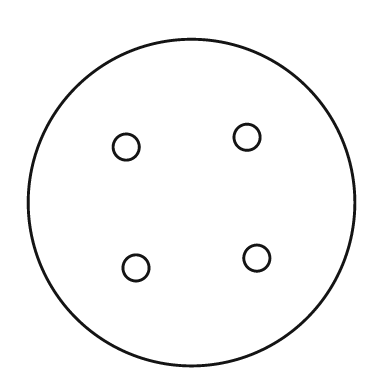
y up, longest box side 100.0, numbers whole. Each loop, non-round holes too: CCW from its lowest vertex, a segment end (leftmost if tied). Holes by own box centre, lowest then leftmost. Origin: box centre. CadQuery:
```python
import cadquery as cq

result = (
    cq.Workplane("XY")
    .moveTo(0.0, 0.0)
    .circle(50.0)
    .moveTo(-17.0, -20.0)
    .circle(4.0)
    .moveTo(20.0, -17.0)
    .circle(4.0)
    .moveTo(-20.0, 17.0)
    .circle(4.0)
    .moveTo(17.0, 20.0)
    .circle(4.0)
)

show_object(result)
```